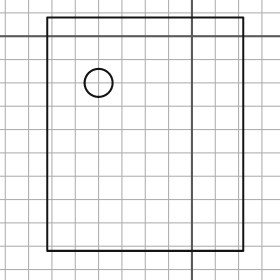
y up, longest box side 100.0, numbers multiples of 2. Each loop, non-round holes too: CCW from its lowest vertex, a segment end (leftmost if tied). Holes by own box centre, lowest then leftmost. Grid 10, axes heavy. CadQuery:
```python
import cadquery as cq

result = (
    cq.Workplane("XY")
    .moveTo(-62.0, -92.0)
    .lineTo(22.0, -92.0)
    .lineTo(22.0, 8.0)
    .lineTo(-62.0, 8.0)
    .close()
    .moveTo(-40.0, -20.0)
    .circle(6.0)
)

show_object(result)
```